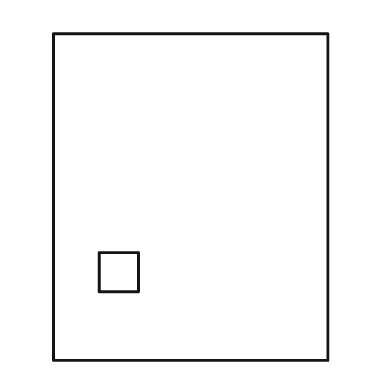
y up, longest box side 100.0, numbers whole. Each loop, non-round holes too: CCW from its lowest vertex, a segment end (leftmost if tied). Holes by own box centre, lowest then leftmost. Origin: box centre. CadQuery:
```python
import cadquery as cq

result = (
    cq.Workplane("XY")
    .moveTo(-42.0, -50.0)
    .lineTo(42.0, -50.0)
    .lineTo(42.0, 50.0)
    .lineTo(-42.0, 50.0)
    .close()
    .moveTo(-28.0, -29.0)
    .lineTo(-16.0, -29.0)
    .lineTo(-16.0, -17.0)
    .lineTo(-28.0, -17.0)
    .close()
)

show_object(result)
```